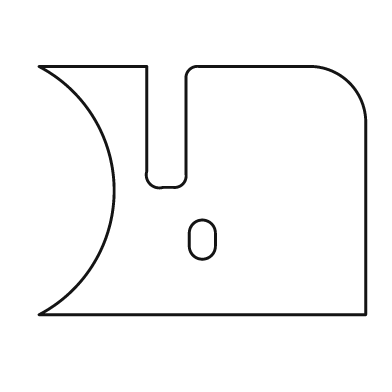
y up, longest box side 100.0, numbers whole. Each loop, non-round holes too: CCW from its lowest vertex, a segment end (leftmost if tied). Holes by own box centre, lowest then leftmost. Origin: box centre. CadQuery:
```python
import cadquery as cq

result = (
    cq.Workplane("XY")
    .moveTo(-50.0, -38.0)
    .lineTo(50.0, -38.0)
    .lineTo(50.0, 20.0)
    .threePointArc((45.0, 33.0), (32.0, 38.0))
    .lineTo(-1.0, 38.0)
    .threePointArc((-4.0, 37.0), (-5.0, 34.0))
    .lineTo(-5.0, 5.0)
    .threePointArc((-6.0, 2.0), (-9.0, 1.0))
    .lineTo(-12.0, 1.0)
    .threePointArc((-16.0, 2.0), (-17.0, 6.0))
    .lineTo(-17.0, 38.0)
    .lineTo(-50.0, 38.0)
    .threePointArc((-27.0, 0.0), (-50.0, -38.0))
    .close()
    .moveTo(-4.0, -17.0)
    .threePointArc((0.0, -21.0), (4.0, -17.0))
    .lineTo(4.0, -13.0)
    .threePointArc((0.0, -9.0), (-4.0, -13.0))
    .close()
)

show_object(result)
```